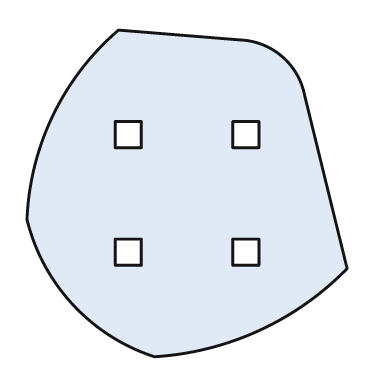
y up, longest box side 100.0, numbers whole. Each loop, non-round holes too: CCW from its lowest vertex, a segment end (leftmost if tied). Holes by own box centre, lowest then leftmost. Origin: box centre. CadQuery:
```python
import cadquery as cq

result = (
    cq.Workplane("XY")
    .moveTo(-10.0, -50.0)
    .threePointArc((22.0, -42.0), (49.0, -23.0))
    .lineTo(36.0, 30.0)
    .threePointArc((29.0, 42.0), (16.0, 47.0))
    .lineTo(-21.0, 50.0)
    .threePointArc((-41.0, 24.0), (-49.0, -8.0))
    .threePointArc((-35.0, -34.0), (-10.0, -50.0))
    .close()
    .moveTo(-22.0, -22.0)
    .lineTo(-14.0, -22.0)
    .lineTo(-14.0, -14.0)
    .lineTo(-22.0, -14.0)
    .close()
    .moveTo(14.0, -22.0)
    .lineTo(22.0, -22.0)
    .lineTo(22.0, -14.0)
    .lineTo(14.0, -14.0)
    .close()
    .moveTo(-22.0, 14.0)
    .lineTo(-14.0, 14.0)
    .lineTo(-14.0, 22.0)
    .lineTo(-22.0, 22.0)
    .close()
    .moveTo(14.0, 14.0)
    .lineTo(22.0, 14.0)
    .lineTo(22.0, 22.0)
    .lineTo(14.0, 22.0)
    .close()
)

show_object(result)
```